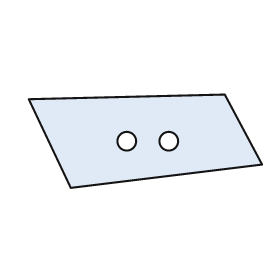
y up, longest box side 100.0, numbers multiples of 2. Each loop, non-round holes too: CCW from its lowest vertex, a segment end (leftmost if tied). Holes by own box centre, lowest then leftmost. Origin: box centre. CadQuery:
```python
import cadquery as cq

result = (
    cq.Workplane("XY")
    .moveTo(-32.0, -20.0)
    .lineTo(50.0, -10.0)
    .lineTo(34.0, 20.0)
    .lineTo(-50.0, 18.0)
    .close()
    .moveTo(-8.0, 0.0)
    .circle(4.0)
    .moveTo(10.0, 0.0)
    .circle(4.0)
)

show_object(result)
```